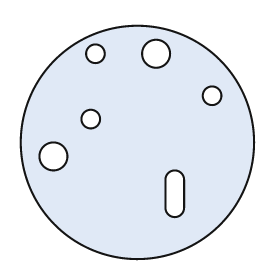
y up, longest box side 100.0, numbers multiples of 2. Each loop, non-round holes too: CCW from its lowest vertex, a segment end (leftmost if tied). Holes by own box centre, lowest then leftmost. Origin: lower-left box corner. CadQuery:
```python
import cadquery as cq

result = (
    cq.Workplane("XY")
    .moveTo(50.0, 50.0)
    .circle(50.0)
    .moveTo(62.0, 22.0)
    .threePointArc((66.0, 18.0), (70.0, 22.0))
    .lineTo(70.0, 34.0)
    .threePointArc((66.0, 38.0), (62.0, 34.0))
    .close()
    .moveTo(14.0, 44.0)
    .circle(6.0)
    .moveTo(30.0, 60.0)
    .circle(4.0)
    .moveTo(82.0, 70.0)
    .circle(4.0)
    .moveTo(32.0, 88.0)
    .circle(4.0)
    .moveTo(58.0, 88.0)
    .circle(6.0)
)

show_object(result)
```